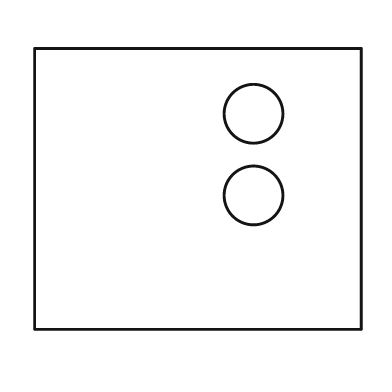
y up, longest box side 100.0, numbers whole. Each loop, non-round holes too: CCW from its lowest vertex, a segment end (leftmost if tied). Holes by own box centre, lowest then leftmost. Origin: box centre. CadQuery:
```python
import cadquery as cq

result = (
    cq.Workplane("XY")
    .moveTo(-50.0, -43.0)
    .lineTo(50.0, -43.0)
    .lineTo(50.0, 43.0)
    .lineTo(-50.0, 43.0)
    .close()
    .moveTo(17.0, -2.0)
    .circle(9.0)
    .moveTo(17.0, 23.0)
    .circle(9.0)
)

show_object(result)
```